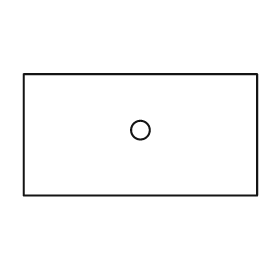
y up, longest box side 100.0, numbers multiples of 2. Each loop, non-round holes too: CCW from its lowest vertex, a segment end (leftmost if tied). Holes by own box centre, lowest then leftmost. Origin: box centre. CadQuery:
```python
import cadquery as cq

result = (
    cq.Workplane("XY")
    .moveTo(-50.0, -26.0)
    .lineTo(50.0, -26.0)
    .lineTo(50.0, 26.0)
    .lineTo(-50.0, 26.0)
    .close()
    .moveTo(0.0, 2.0)
    .circle(4.0)
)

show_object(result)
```